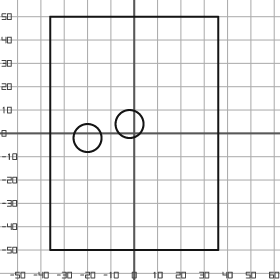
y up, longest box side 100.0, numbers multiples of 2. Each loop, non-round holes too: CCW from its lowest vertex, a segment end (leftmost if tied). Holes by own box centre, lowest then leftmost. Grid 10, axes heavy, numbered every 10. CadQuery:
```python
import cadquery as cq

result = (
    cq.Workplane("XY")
    .moveTo(-36.0, -50.0)
    .lineTo(36.0, -50.0)
    .lineTo(36.0, 50.0)
    .lineTo(-36.0, 50.0)
    .close()
    .moveTo(-20.0, -2.0)
    .circle(6.0)
    .moveTo(-2.0, 4.0)
    .circle(6.0)
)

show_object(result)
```